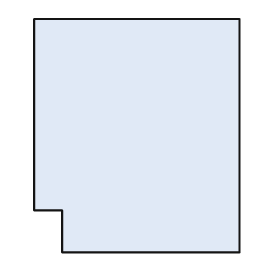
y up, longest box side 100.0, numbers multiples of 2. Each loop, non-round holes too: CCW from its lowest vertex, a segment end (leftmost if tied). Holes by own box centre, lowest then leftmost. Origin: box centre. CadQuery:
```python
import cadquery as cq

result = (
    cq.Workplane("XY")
    .moveTo(-32.0, -50.0)
    .lineTo(44.0, -50.0)
    .lineTo(44.0, 50.0)
    .lineTo(-44.0, 50.0)
    .lineTo(-44.0, -32.0)
    .lineTo(-32.0, -32.0)
    .close()
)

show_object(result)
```